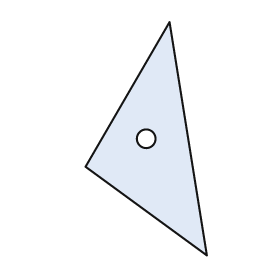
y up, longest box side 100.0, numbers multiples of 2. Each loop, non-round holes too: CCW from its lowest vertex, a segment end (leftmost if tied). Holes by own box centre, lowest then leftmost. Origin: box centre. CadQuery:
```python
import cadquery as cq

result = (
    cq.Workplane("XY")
    .moveTo(26.0, -50.0)
    .lineTo(10.0, 50.0)
    .lineTo(-26.0, -12.0)
    .close()
    .moveTo(0.0, 0.0)
    .circle(4.0)
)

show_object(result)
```